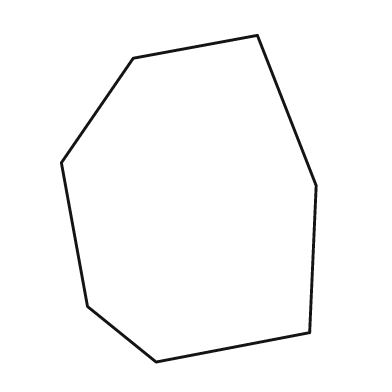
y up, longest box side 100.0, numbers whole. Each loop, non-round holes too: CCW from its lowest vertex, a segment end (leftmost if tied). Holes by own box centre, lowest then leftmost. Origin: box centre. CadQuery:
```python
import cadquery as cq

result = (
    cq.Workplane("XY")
    .moveTo(-10.0, -50.0)
    .lineTo(37.0, -41.0)
    .lineTo(39.0, 4.0)
    .lineTo(21.0, 50.0)
    .lineTo(-17.0, 43.0)
    .lineTo(-39.0, 11.0)
    .lineTo(-31.0, -33.0)
    .close()
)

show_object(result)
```